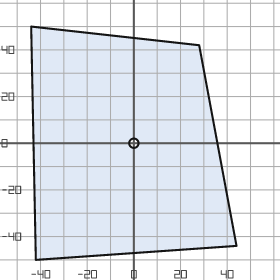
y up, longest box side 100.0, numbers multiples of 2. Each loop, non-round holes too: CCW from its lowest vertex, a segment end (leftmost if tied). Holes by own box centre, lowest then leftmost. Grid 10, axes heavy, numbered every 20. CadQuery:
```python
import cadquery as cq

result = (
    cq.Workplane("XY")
    .moveTo(-42.0, -50.0)
    .lineTo(44.0, -44.0)
    .lineTo(28.0, 42.0)
    .lineTo(-44.0, 50.0)
    .close()
    .moveTo(0.0, 0.0)
    .circle(2.0)
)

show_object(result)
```